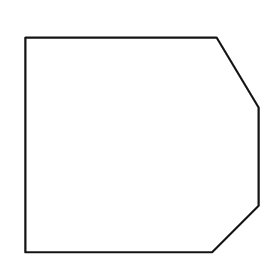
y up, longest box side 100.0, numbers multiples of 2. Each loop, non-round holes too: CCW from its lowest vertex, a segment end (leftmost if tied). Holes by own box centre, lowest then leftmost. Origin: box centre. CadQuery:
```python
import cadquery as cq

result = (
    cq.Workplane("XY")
    .moveTo(-50.0, -46.0)
    .lineTo(30.0, -46.0)
    .lineTo(50.0, -26.0)
    .lineTo(50.0, 16.0)
    .lineTo(32.0, 46.0)
    .lineTo(-50.0, 46.0)
    .close()
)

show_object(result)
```